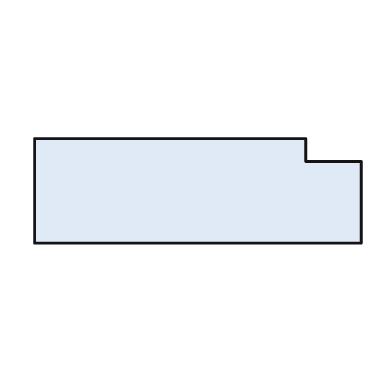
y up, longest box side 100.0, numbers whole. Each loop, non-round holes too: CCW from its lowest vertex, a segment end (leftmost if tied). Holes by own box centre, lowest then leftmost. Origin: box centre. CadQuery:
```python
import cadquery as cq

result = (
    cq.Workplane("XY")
    .moveTo(-50.0, -16.0)
    .lineTo(50.0, -16.0)
    .lineTo(50.0, 9.0)
    .lineTo(33.0, 9.0)
    .lineTo(33.0, 16.0)
    .lineTo(-50.0, 16.0)
    .close()
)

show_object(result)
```